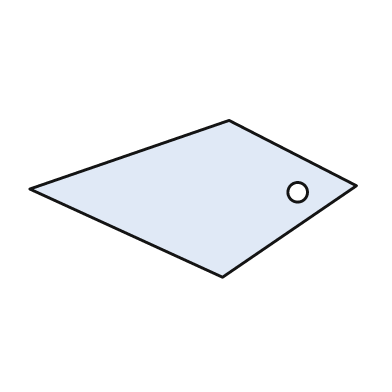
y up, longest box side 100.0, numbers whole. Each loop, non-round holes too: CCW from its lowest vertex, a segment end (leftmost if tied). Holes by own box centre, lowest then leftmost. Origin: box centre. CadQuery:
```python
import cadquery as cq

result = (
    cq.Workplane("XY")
    .moveTo(9.0, -24.0)
    .lineTo(50.0, 4.0)
    .lineTo(11.0, 24.0)
    .lineTo(-50.0, 3.0)
    .close()
    .moveTo(32.0, 2.0)
    .circle(3.0)
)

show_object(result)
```